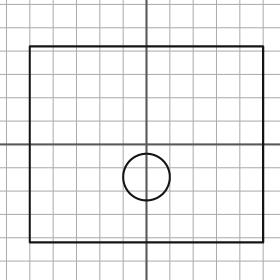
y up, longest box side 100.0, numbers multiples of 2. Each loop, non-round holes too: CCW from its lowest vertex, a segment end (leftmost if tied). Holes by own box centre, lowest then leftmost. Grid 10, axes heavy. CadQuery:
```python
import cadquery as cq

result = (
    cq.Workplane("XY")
    .moveTo(-50.0, -42.0)
    .lineTo(50.0, -42.0)
    .lineTo(50.0, 42.0)
    .lineTo(-50.0, 42.0)
    .close()
    .moveTo(0.0, -14.0)
    .circle(10.0)
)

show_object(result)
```